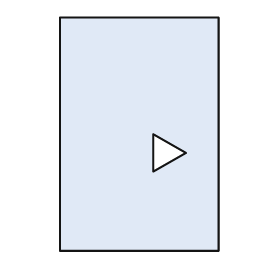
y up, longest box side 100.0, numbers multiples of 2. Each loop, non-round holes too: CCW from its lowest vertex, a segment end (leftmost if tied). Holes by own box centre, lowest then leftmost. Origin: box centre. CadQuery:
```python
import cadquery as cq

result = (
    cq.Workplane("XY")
    .moveTo(-34.0, -50.0)
    .lineTo(34.0, -50.0)
    .lineTo(34.0, 50.0)
    .lineTo(-34.0, 50.0)
    .close()
    .moveTo(6.0, -16.0)
    .lineTo(20.0, -8.0)
    .lineTo(6.0, 0.0)
    .close()
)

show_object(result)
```